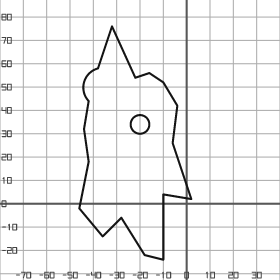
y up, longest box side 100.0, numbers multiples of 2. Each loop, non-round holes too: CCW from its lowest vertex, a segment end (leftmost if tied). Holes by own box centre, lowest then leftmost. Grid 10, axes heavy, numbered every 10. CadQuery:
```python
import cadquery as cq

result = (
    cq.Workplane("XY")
    .moveTo(-10.0, -24.0)
    .lineTo(-10.0, 4.0)
    .lineTo(2.0, 2.0)
    .lineTo(-6.0, 26.0)
    .lineTo(-4.0, 42.0)
    .lineTo(-10.0, 52.0)
    .lineTo(-16.0, 56.0)
    .lineTo(-22.0, 54.0)
    .lineTo(-32.0, 76.0)
    .lineTo(-38.0, 58.0)
    .threePointArc((-44.0, 52.0), (-42.0, 44.0))
    .lineTo(-44.0, 32.0)
    .lineTo(-42.0, 18.0)
    .lineTo(-46.0, -2.0)
    .lineTo(-36.0, -14.0)
    .lineTo(-28.0, -6.0)
    .lineTo(-18.0, -22.0)
    .close()
    .moveTo(-20.0, 34.0)
    .circle(4.0)
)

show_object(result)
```